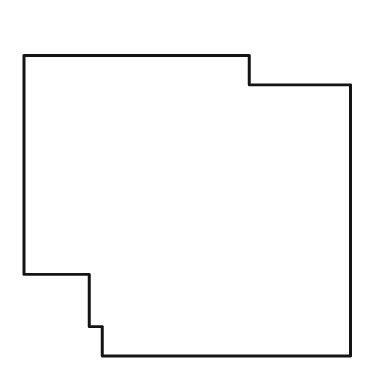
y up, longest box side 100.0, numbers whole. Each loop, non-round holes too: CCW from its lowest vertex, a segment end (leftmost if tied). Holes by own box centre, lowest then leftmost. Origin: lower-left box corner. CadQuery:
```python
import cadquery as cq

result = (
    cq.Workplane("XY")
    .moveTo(24.0, 0.0)
    .lineTo(100.0, 0.0)
    .lineTo(100.0, 83.0)
    .lineTo(69.0, 83.0)
    .lineTo(69.0, 92.0)
    .lineTo(0.0, 92.0)
    .lineTo(0.0, 25.0)
    .lineTo(20.0, 25.0)
    .lineTo(20.0, 9.0)
    .lineTo(24.0, 9.0)
    .close()
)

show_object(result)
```